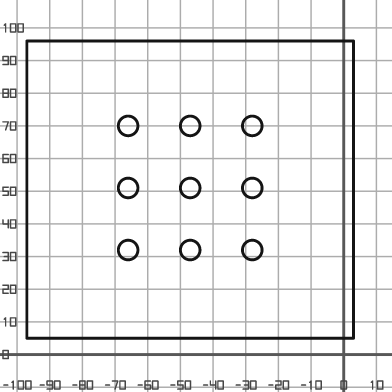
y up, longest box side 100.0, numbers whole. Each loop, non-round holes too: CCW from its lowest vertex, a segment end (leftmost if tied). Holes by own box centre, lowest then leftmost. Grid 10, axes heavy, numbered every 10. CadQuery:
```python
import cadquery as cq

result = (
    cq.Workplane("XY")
    .moveTo(-97.0, 5.0)
    .lineTo(3.0, 5.0)
    .lineTo(3.0, 96.0)
    .lineTo(-97.0, 96.0)
    .close()
    .moveTo(-66.0, 32.0)
    .circle(3.0)
    .moveTo(-47.0, 32.0)
    .circle(3.0)
    .moveTo(-28.0, 32.0)
    .circle(3.0)
    .moveTo(-66.0, 51.0)
    .circle(3.0)
    .moveTo(-47.0, 51.0)
    .circle(3.0)
    .moveTo(-28.0, 51.0)
    .circle(3.0)
    .moveTo(-66.0, 70.0)
    .circle(3.0)
    .moveTo(-47.0, 70.0)
    .circle(3.0)
    .moveTo(-28.0, 70.0)
    .circle(3.0)
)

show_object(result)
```